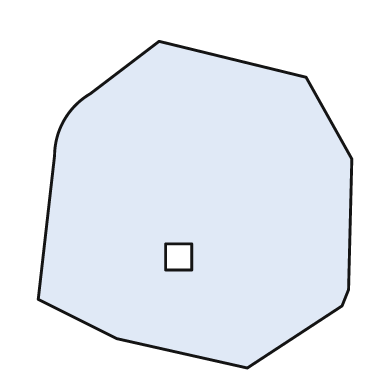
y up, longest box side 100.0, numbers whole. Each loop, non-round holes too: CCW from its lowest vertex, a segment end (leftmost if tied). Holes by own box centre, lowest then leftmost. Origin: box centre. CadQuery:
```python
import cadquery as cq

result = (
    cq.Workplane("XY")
    .moveTo(16.0, -50.0)
    .lineTo(45.0, -31.0)
    .lineTo(47.0, -26.0)
    .lineTo(48.0, 14.0)
    .lineTo(34.0, 39.0)
    .lineTo(-11.0, 50.0)
    .lineTo(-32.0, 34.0)
    .threePointArc((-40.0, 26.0), (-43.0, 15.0))
    .lineTo(-48.0, -29.0)
    .lineTo(-24.0, -41.0)
    .close()
    .moveTo(-9.0, -20.0)
    .lineTo(-1.0, -20.0)
    .lineTo(-1.0, -12.0)
    .lineTo(-9.0, -12.0)
    .close()
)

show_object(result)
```